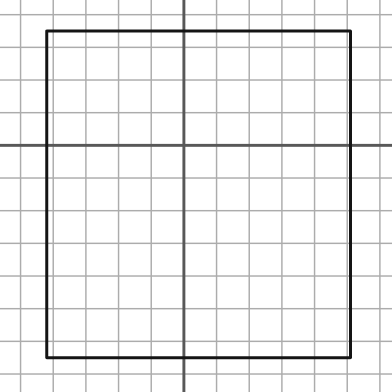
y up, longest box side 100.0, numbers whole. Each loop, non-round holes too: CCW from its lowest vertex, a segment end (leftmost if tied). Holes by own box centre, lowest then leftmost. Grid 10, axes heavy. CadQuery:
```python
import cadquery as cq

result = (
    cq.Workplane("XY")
    .moveTo(-42.0, -65.0)
    .lineTo(51.0, -65.0)
    .lineTo(51.0, 35.0)
    .lineTo(-42.0, 35.0)
    .close()
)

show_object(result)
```